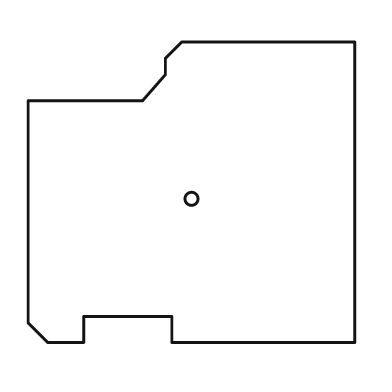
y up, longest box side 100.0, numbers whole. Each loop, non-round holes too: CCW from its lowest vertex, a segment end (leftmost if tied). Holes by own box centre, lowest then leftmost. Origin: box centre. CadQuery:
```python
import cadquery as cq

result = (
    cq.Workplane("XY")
    .moveTo(-44.0, -46.0)
    .lineTo(-33.0, -46.0)
    .lineTo(-33.0, -38.0)
    .lineTo(-6.0, -38.0)
    .lineTo(-6.0, -46.0)
    .lineTo(50.0, -46.0)
    .lineTo(50.0, 46.0)
    .lineTo(-3.0, 46.0)
    .lineTo(-8.0, 41.0)
    .lineTo(-8.0, 36.0)
    .lineTo(-15.0, 28.0)
    .lineTo(-50.0, 28.0)
    .lineTo(-50.0, -40.0)
    .close()
    .moveTo(0.0, -2.0)
    .circle(2.0)
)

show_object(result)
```